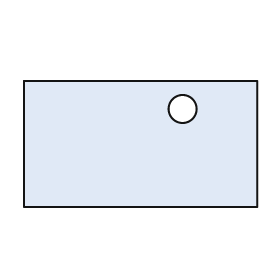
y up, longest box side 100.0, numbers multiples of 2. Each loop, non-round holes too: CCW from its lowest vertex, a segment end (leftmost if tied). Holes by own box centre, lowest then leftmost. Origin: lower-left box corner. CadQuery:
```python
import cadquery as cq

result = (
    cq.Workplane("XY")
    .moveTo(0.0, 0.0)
    .lineTo(100.0, 0.0)
    .lineTo(100.0, 54.0)
    .lineTo(0.0, 54.0)
    .close()
    .moveTo(68.0, 42.0)
    .circle(6.0)
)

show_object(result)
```